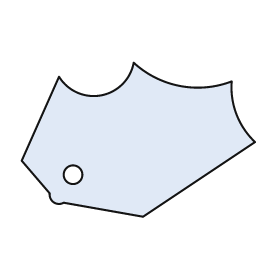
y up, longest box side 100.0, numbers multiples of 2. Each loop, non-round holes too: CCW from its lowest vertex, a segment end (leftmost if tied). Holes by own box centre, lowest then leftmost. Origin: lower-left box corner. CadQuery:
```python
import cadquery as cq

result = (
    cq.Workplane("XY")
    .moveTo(52.0, 0.0)
    .lineTo(100.0, 32.0)
    .threePointArc((92.0, 44.0), (90.0, 58.0))
    .threePointArc((68.0, 56.0), (48.0, 66.0))
    .threePointArc((34.0, 52.0), (16.0, 60.0))
    .lineTo(0.0, 24.0)
    .lineTo(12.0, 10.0)
    .threePointArc((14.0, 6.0), (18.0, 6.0))
    .close()
    .moveTo(22.0, 18.0)
    .circle(4.0)
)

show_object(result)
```